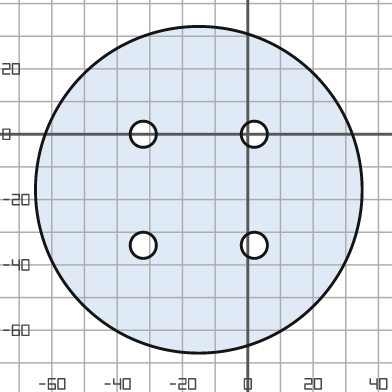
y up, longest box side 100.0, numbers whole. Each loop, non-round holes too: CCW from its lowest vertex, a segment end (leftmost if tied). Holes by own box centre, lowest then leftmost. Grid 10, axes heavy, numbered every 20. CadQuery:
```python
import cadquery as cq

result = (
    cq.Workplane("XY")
    .moveTo(-15.0, -17.0)
    .circle(50.0)
    .moveTo(-32.0, -34.0)
    .circle(4.0)
    .moveTo(2.0, -34.0)
    .circle(4.0)
    .moveTo(-32.0, 0.0)
    .circle(4.0)
    .moveTo(2.0, 0.0)
    .circle(4.0)
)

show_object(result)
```